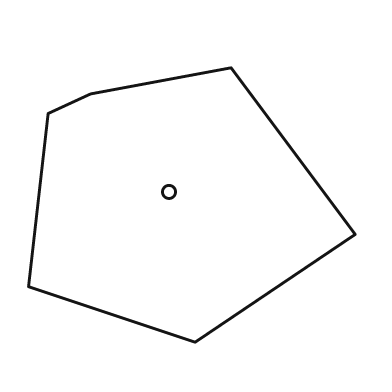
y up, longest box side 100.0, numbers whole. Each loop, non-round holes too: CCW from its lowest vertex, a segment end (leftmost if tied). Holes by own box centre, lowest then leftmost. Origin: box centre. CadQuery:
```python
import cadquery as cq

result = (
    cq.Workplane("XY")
    .moveTo(1.0, -42.0)
    .lineTo(50.0, -9.0)
    .lineTo(12.0, 42.0)
    .lineTo(-31.0, 34.0)
    .lineTo(-44.0, 28.0)
    .lineTo(-50.0, -25.0)
    .close()
    .moveTo(-7.0, 4.0)
    .circle(2.0)
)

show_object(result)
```